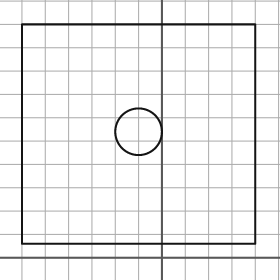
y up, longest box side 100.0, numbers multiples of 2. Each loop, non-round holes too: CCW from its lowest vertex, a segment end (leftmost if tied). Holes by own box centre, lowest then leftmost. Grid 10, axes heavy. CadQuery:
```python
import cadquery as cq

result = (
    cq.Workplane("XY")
    .moveTo(-60.0, 6.0)
    .lineTo(40.0, 6.0)
    .lineTo(40.0, 100.0)
    .lineTo(-60.0, 100.0)
    .close()
    .moveTo(-10.0, 54.0)
    .circle(10.0)
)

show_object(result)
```